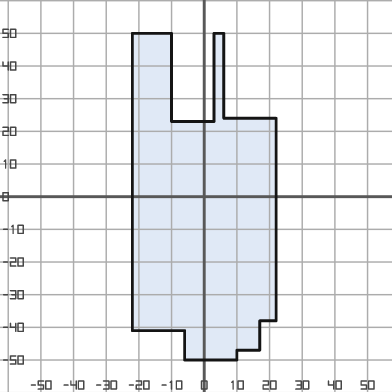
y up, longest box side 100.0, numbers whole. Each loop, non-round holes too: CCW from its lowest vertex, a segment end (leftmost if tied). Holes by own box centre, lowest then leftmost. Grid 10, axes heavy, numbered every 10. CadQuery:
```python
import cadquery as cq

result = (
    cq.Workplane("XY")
    .moveTo(-6.0, -50.0)
    .lineTo(10.0, -50.0)
    .lineTo(10.0, -47.0)
    .lineTo(17.0, -47.0)
    .lineTo(17.0, -38.0)
    .lineTo(22.0, -38.0)
    .lineTo(22.0, 24.0)
    .lineTo(6.0, 24.0)
    .lineTo(6.0, 50.0)
    .lineTo(3.0, 50.0)
    .lineTo(3.0, 23.0)
    .lineTo(-10.0, 23.0)
    .lineTo(-10.0, 50.0)
    .lineTo(-22.0, 50.0)
    .lineTo(-22.0, -41.0)
    .lineTo(-6.0, -41.0)
    .close()
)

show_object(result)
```